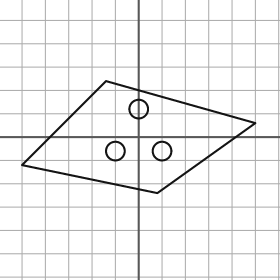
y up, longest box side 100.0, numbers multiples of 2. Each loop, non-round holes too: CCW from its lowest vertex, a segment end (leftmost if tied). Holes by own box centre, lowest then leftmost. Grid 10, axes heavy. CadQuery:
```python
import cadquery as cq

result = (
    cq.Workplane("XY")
    .moveTo(8.0, -24.0)
    .lineTo(50.0, 6.0)
    .lineTo(-14.0, 24.0)
    .lineTo(-50.0, -12.0)
    .close()
    .moveTo(-10.0, -6.0)
    .circle(4.0)
    .moveTo(10.0, -6.0)
    .circle(4.0)
    .moveTo(0.0, 12.0)
    .circle(4.0)
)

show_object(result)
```